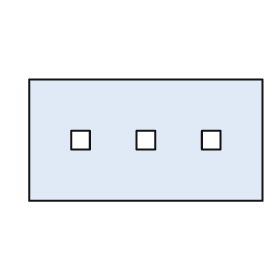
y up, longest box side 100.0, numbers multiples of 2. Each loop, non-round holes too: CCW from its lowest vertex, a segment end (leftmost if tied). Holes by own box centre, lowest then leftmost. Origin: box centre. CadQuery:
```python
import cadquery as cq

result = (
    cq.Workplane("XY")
    .moveTo(-50.0, -26.0)
    .lineTo(50.0, -26.0)
    .lineTo(50.0, 26.0)
    .lineTo(-50.0, 26.0)
    .close()
    .moveTo(-32.0, -4.0)
    .lineTo(-24.0, -4.0)
    .lineTo(-24.0, 4.0)
    .lineTo(-32.0, 4.0)
    .close()
    .moveTo(-4.0, -4.0)
    .lineTo(4.0, -4.0)
    .lineTo(4.0, 4.0)
    .lineTo(-4.0, 4.0)
    .close()
    .moveTo(24.0, -4.0)
    .lineTo(32.0, -4.0)
    .lineTo(32.0, 4.0)
    .lineTo(24.0, 4.0)
    .close()
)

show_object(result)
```